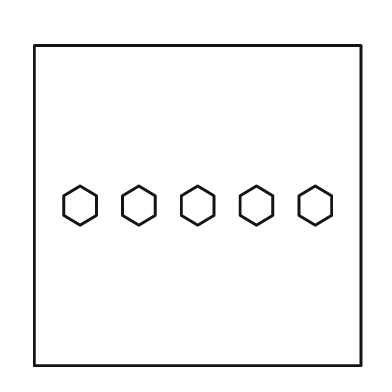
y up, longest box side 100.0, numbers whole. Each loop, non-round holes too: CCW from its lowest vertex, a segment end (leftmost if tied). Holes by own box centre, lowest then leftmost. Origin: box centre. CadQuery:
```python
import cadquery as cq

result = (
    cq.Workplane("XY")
    .moveTo(-50.0, -49.0)
    .lineTo(50.0, -49.0)
    .lineTo(50.0, 49.0)
    .lineTo(-50.0, 49.0)
    .close()
    .moveTo(-36.0, -6.0)
    .lineTo(-31.0, -3.0)
    .lineTo(-31.0, 3.0)
    .lineTo(-36.0, 6.0)
    .lineTo(-41.0, 3.0)
    .lineTo(-41.0, -3.0)
    .close()
    .moveTo(-18.0, -6.0)
    .lineTo(-13.0, -3.0)
    .lineTo(-13.0, 3.0)
    .lineTo(-18.0, 6.0)
    .lineTo(-23.0, 3.0)
    .lineTo(-23.0, -3.0)
    .close()
    .moveTo(0.0, -6.0)
    .lineTo(5.0, -3.0)
    .lineTo(5.0, 3.0)
    .lineTo(0.0, 6.0)
    .lineTo(-5.0, 3.0)
    .lineTo(-5.0, -3.0)
    .close()
    .moveTo(18.0, -6.0)
    .lineTo(23.0, -3.0)
    .lineTo(23.0, 3.0)
    .lineTo(18.0, 6.0)
    .lineTo(13.0, 3.0)
    .lineTo(13.0, -3.0)
    .close()
    .moveTo(36.0, -6.0)
    .lineTo(41.0, -3.0)
    .lineTo(41.0, 3.0)
    .lineTo(36.0, 6.0)
    .lineTo(31.0, 3.0)
    .lineTo(31.0, -3.0)
    .close()
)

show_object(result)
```